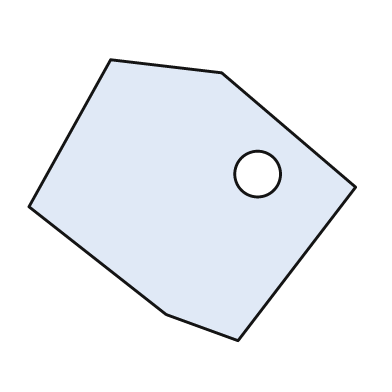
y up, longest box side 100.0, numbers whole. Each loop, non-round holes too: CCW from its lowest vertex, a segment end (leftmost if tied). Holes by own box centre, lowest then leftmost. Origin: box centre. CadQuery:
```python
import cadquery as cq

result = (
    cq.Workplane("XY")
    .moveTo(14.0, -43.0)
    .lineTo(50.0, 4.0)
    .lineTo(9.0, 39.0)
    .lineTo(-25.0, 43.0)
    .lineTo(-50.0, -2.0)
    .lineTo(-8.0, -35.0)
    .close()
    .moveTo(20.0, 8.0)
    .circle(7.0)
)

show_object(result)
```